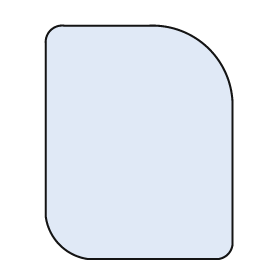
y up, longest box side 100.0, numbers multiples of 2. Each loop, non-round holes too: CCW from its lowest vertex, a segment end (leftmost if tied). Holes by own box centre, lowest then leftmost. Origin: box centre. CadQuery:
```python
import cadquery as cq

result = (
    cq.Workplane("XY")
    .moveTo(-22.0, -50.0)
    .lineTo(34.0, -50.0)
    .threePointArc((38.0, -48.0), (40.0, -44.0))
    .lineTo(40.0, 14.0)
    .threePointArc((30.0, 40.0), (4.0, 50.0))
    .lineTo(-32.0, 50.0)
    .threePointArc((-38.0, 48.0), (-40.0, 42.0))
    .lineTo(-40.0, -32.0)
    .threePointArc((-34.0, -44.0), (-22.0, -50.0))
    .close()
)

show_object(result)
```